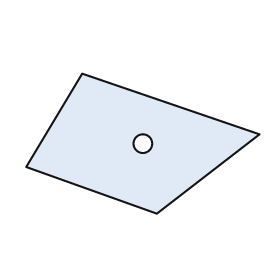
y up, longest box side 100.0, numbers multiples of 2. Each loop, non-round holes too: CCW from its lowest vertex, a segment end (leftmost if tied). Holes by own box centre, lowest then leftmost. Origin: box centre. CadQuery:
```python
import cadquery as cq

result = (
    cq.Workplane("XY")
    .moveTo(6.0, -30.0)
    .lineTo(50.0, 4.0)
    .lineTo(-26.0, 30.0)
    .lineTo(-50.0, -10.0)
    .close()
    .moveTo(0.0, 0.0)
    .circle(4.0)
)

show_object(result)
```